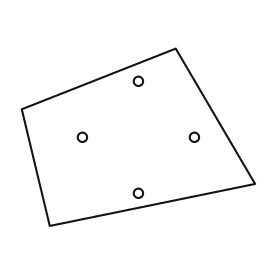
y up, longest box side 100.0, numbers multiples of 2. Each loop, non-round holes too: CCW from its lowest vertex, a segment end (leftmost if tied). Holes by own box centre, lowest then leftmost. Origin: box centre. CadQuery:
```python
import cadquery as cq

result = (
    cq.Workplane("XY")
    .moveTo(-38.0, -38.0)
    .lineTo(50.0, -20.0)
    .lineTo(16.0, 38.0)
    .lineTo(-50.0, 12.0)
    .close()
    .moveTo(0.0, -24.0)
    .circle(2.0)
    .moveTo(-24.0, 0.0)
    .circle(2.0)
    .moveTo(24.0, 0.0)
    .circle(2.0)
    .moveTo(0.0, 24.0)
    .circle(2.0)
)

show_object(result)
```